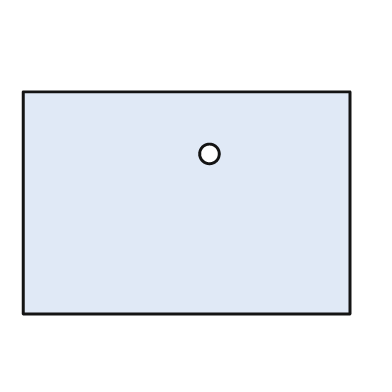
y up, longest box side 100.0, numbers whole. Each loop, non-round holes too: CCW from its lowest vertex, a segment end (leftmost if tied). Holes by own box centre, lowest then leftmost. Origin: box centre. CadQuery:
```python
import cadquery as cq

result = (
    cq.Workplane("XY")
    .moveTo(-50.0, -34.0)
    .lineTo(50.0, -34.0)
    .lineTo(50.0, 34.0)
    .lineTo(-50.0, 34.0)
    .close()
    .moveTo(7.0, 15.0)
    .circle(3.0)
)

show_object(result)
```